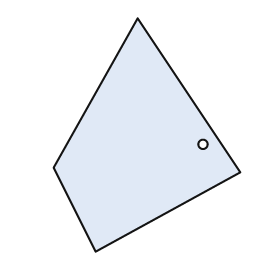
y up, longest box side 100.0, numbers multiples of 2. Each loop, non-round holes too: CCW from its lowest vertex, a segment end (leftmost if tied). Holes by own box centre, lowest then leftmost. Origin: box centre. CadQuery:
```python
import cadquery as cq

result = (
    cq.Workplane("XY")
    .moveTo(-22.0, -50.0)
    .lineTo(40.0, -16.0)
    .lineTo(-4.0, 50.0)
    .lineTo(-40.0, -14.0)
    .close()
    .moveTo(24.0, -4.0)
    .circle(2.0)
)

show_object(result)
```